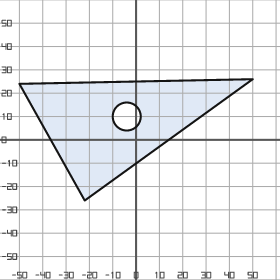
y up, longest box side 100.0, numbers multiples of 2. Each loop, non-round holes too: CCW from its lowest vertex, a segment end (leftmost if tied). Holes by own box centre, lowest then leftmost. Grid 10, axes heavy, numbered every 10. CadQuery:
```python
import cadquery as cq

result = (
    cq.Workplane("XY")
    .moveTo(-22.0, -26.0)
    .lineTo(50.0, 26.0)
    .lineTo(-50.0, 24.0)
    .close()
    .moveTo(-4.0, 10.0)
    .circle(6.0)
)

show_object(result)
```